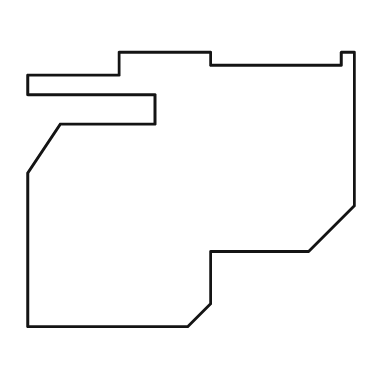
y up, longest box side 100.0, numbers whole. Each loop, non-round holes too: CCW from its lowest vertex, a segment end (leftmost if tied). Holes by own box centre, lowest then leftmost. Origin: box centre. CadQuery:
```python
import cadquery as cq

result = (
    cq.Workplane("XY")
    .moveTo(-50.0, -42.0)
    .lineTo(-1.0, -42.0)
    .lineTo(6.0, -35.0)
    .lineTo(6.0, -19.0)
    .lineTo(36.0, -19.0)
    .lineTo(50.0, -5.0)
    .lineTo(50.0, 42.0)
    .lineTo(46.0, 42.0)
    .lineTo(46.0, 38.0)
    .lineTo(6.0, 38.0)
    .lineTo(6.0, 42.0)
    .lineTo(-22.0, 42.0)
    .lineTo(-22.0, 35.0)
    .lineTo(-50.0, 35.0)
    .lineTo(-50.0, 29.0)
    .lineTo(-11.0, 29.0)
    .lineTo(-11.0, 20.0)
    .lineTo(-40.0, 20.0)
    .lineTo(-50.0, 5.0)
    .close()
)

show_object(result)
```